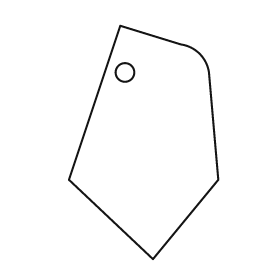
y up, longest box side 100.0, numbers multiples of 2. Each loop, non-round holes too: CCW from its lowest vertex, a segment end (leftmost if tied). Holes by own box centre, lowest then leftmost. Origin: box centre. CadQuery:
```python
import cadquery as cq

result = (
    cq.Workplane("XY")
    .moveTo(4.0, -50.0)
    .lineTo(32.0, -16.0)
    .lineTo(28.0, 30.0)
    .threePointArc((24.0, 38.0), (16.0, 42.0))
    .lineTo(-10.0, 50.0)
    .lineTo(-32.0, -16.0)
    .close()
    .moveTo(-8.0, 30.0)
    .circle(4.0)
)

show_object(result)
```